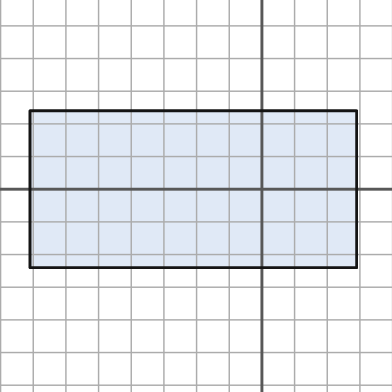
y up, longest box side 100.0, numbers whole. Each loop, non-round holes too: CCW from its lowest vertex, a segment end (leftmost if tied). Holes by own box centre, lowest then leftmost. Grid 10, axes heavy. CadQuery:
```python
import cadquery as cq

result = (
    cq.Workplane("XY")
    .moveTo(-71.0, -24.0)
    .lineTo(29.0, -24.0)
    .lineTo(29.0, 24.0)
    .lineTo(-71.0, 24.0)
    .close()
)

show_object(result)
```